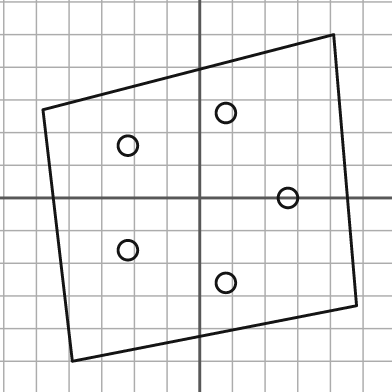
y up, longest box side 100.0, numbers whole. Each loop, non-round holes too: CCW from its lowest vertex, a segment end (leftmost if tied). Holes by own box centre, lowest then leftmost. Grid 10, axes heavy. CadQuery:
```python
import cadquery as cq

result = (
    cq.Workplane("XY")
    .moveTo(-39.0, -50.0)
    .lineTo(48.0, -33.0)
    .lineTo(41.0, 50.0)
    .lineTo(-48.0, 27.0)
    .close()
    .moveTo(8.0, -26.0)
    .circle(3.0)
    .moveTo(-22.0, -16.0)
    .circle(3.0)
    .moveTo(27.0, 0.0)
    .circle(3.0)
    .moveTo(-22.0, 16.0)
    .circle(3.0)
    .moveTo(8.0, 26.0)
    .circle(3.0)
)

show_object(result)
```